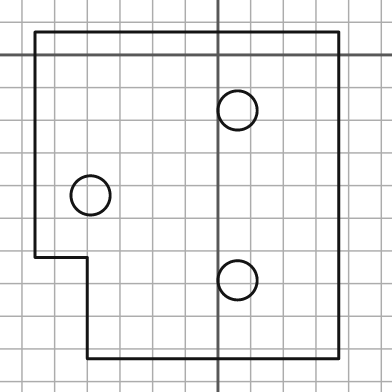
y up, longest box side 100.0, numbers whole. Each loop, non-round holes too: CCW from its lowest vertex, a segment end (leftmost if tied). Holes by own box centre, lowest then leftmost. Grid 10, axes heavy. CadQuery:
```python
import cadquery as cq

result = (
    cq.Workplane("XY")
    .moveTo(-40.0, -93.0)
    .lineTo(37.0, -93.0)
    .lineTo(37.0, 7.0)
    .lineTo(-56.0, 7.0)
    .lineTo(-56.0, -62.0)
    .lineTo(-40.0, -62.0)
    .close()
    .moveTo(6.0, -69.0)
    .circle(6.0)
    .moveTo(-39.0, -43.0)
    .circle(6.0)
    .moveTo(6.0, -17.0)
    .circle(6.0)
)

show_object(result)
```